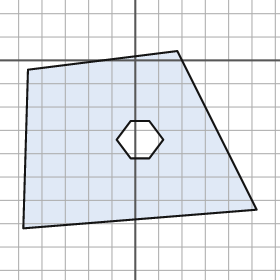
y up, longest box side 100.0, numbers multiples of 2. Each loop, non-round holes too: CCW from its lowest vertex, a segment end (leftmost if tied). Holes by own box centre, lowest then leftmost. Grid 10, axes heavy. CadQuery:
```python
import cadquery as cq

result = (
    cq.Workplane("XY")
    .moveTo(-48.0, -72.0)
    .lineTo(52.0, -64.0)
    .lineTo(18.0, 4.0)
    .lineTo(-46.0, -4.0)
    .close()
    .moveTo(-2.0, -42.0)
    .lineTo(6.0, -42.0)
    .lineTo(12.0, -34.0)
    .lineTo(6.0, -26.0)
    .lineTo(-2.0, -26.0)
    .lineTo(-8.0, -34.0)
    .close()
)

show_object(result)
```